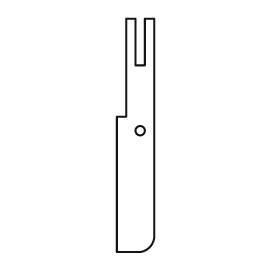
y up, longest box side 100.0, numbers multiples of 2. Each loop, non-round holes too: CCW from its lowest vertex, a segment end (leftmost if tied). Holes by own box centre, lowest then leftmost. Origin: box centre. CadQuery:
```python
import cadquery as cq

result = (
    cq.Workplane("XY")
    .moveTo(-8.0, -50.0)
    .lineTo(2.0, -50.0)
    .threePointArc((6.0, -48.0), (8.0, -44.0))
    .lineTo(8.0, 50.0)
    .lineTo(4.0, 50.0)
    .lineTo(4.0, 30.0)
    .lineTo(0.0, 30.0)
    .lineTo(0.0, 50.0)
    .lineTo(-4.0, 50.0)
    .lineTo(-4.0, 8.0)
    .lineTo(-8.0, 8.0)
    .close()
    .moveTo(2.0, 2.0)
    .circle(2.0)
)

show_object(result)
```